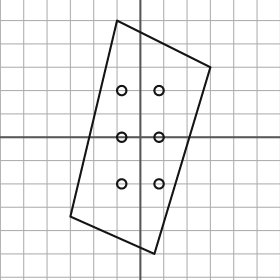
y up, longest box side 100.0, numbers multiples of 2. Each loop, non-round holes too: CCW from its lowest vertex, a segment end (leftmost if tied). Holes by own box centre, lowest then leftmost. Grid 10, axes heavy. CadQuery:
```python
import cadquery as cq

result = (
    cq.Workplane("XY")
    .moveTo(6.0, -50.0)
    .lineTo(30.0, 30.0)
    .lineTo(-10.0, 50.0)
    .lineTo(-30.0, -34.0)
    .close()
    .moveTo(-8.0, -20.0)
    .circle(2.0)
    .moveTo(8.0, -20.0)
    .circle(2.0)
    .moveTo(-8.0, 0.0)
    .circle(2.0)
    .moveTo(8.0, 0.0)
    .circle(2.0)
    .moveTo(-8.0, 20.0)
    .circle(2.0)
    .moveTo(8.0, 20.0)
    .circle(2.0)
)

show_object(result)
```